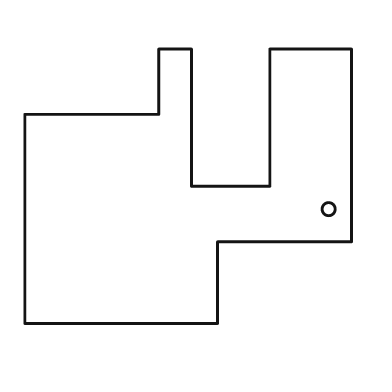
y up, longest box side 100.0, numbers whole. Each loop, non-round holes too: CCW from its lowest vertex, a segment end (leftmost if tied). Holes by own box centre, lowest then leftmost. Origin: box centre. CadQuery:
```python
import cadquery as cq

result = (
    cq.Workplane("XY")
    .moveTo(-50.0, -42.0)
    .lineTo(9.0, -42.0)
    .lineTo(9.0, -17.0)
    .lineTo(50.0, -17.0)
    .lineTo(50.0, 42.0)
    .lineTo(25.0, 42.0)
    .lineTo(25.0, 0.0)
    .lineTo(1.0, 0.0)
    .lineTo(1.0, 42.0)
    .lineTo(-9.0, 42.0)
    .lineTo(-9.0, 22.0)
    .lineTo(-50.0, 22.0)
    .close()
    .moveTo(43.0, -7.0)
    .circle(2.0)
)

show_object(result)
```